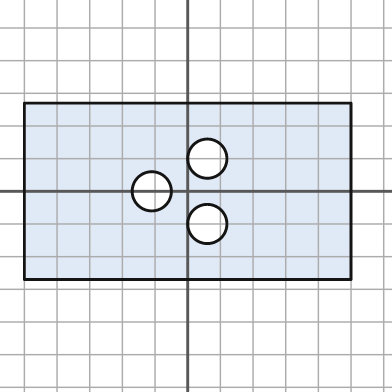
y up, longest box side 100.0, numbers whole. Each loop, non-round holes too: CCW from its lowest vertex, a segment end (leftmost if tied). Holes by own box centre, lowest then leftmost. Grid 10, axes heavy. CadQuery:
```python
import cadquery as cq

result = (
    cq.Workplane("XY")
    .moveTo(-50.0, -27.0)
    .lineTo(50.0, -27.0)
    .lineTo(50.0, 27.0)
    .lineTo(-50.0, 27.0)
    .close()
    .moveTo(6.0, -10.0)
    .circle(6.0)
    .moveTo(-11.0, 0.0)
    .circle(6.0)
    .moveTo(6.0, 10.0)
    .circle(6.0)
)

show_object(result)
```